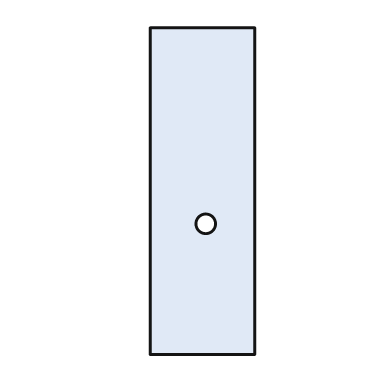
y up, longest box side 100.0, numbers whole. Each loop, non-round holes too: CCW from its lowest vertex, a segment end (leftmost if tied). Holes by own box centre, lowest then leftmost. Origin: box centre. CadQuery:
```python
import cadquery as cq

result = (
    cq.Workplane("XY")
    .moveTo(-16.0, -50.0)
    .lineTo(16.0, -50.0)
    .lineTo(16.0, 50.0)
    .lineTo(-16.0, 50.0)
    .close()
    .moveTo(1.0, -10.0)
    .circle(3.0)
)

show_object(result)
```